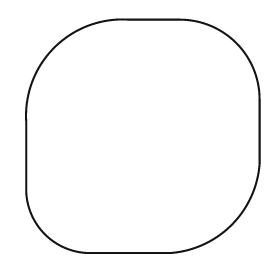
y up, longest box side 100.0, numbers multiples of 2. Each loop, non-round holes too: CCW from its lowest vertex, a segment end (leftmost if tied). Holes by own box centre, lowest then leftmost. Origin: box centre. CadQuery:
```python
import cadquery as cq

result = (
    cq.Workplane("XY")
    .moveTo(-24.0, -50.0)
    .lineTo(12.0, -50.0)
    .threePointArc((38.0, -38.0), (50.0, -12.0))
    .lineTo(50.0, 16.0)
    .threePointArc((40.0, 40.0), (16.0, 50.0))
    .lineTo(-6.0, 50.0)
    .threePointArc((-38.0, 38.0), (-50.0, 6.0))
    .lineTo(-50.0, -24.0)
    .threePointArc((-42.0, -42.0), (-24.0, -50.0))
    .close()
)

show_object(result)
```